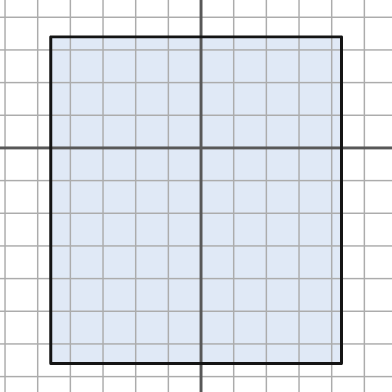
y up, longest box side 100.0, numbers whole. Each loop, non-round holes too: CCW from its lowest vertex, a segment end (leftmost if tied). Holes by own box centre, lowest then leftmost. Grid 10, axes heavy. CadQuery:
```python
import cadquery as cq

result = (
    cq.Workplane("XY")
    .moveTo(-46.0, -66.0)
    .lineTo(43.0, -66.0)
    .lineTo(43.0, 34.0)
    .lineTo(-46.0, 34.0)
    .close()
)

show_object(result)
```